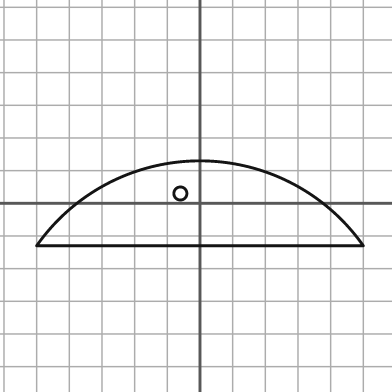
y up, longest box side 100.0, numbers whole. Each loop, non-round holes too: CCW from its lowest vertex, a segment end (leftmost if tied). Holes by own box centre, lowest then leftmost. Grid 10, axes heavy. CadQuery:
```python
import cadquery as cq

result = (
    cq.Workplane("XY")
    .moveTo(-50.0, -13.0)
    .lineTo(50.0, -13.0)
    .threePointArc((0.0, 13.0), (-50.0, -13.0))
    .close()
    .moveTo(-6.0, 3.0)
    .circle(2.0)
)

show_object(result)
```